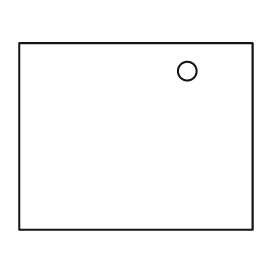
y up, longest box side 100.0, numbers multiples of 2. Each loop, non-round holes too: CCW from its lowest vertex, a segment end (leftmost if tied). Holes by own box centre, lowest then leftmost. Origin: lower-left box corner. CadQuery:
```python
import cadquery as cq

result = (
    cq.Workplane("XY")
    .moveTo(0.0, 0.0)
    .lineTo(100.0, 0.0)
    .lineTo(100.0, 80.0)
    .lineTo(0.0, 80.0)
    .close()
    .moveTo(72.0, 68.0)
    .circle(4.0)
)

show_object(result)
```